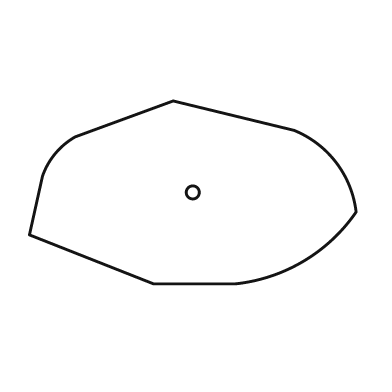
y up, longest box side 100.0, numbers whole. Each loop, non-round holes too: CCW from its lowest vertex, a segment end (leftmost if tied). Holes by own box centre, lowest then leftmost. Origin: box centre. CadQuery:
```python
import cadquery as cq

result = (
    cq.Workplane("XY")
    .moveTo(-12.0, -28.0)
    .lineTo(13.0, -28.0)
    .threePointArc((34.0, -21.0), (50.0, -6.0))
    .threePointArc((44.0, 9.0), (31.0, 19.0))
    .lineTo(-6.0, 28.0)
    .lineTo(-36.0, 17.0)
    .threePointArc((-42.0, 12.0), (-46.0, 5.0))
    .lineTo(-50.0, -13.0)
    .close()
    .moveTo(0.0, 0.0)
    .circle(2.0)
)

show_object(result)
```